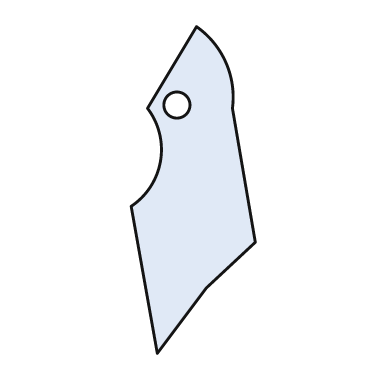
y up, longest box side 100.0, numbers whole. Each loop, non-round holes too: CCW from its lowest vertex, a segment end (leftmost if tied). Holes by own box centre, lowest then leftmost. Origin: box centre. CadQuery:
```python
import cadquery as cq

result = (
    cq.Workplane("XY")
    .moveTo(-11.0, -50.0)
    .lineTo(4.0, -30.0)
    .lineTo(19.0, -16.0)
    .lineTo(12.0, 25.0)
    .threePointArc((10.0, 39.0), (1.0, 50.0))
    .lineTo(-14.0, 25.0)
    .threePointArc((-10.0, 9.0), (-19.0, -5.0))
    .close()
    .moveTo(-5.0, 26.0)
    .circle(4.0)
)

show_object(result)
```